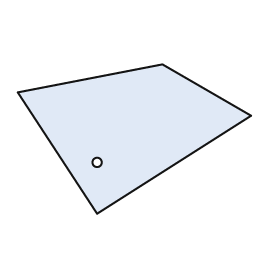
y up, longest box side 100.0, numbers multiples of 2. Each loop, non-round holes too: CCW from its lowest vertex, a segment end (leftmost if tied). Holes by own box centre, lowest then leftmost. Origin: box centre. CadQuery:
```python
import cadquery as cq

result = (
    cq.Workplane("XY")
    .moveTo(-16.0, -32.0)
    .lineTo(50.0, 10.0)
    .lineTo(12.0, 32.0)
    .lineTo(-50.0, 20.0)
    .close()
    .moveTo(-16.0, -10.0)
    .circle(2.0)
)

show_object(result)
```